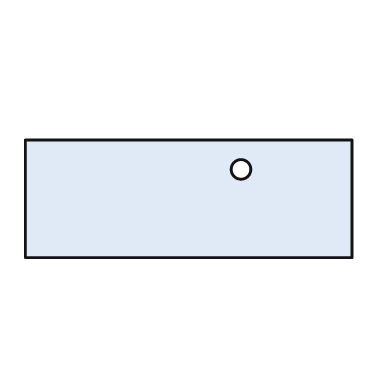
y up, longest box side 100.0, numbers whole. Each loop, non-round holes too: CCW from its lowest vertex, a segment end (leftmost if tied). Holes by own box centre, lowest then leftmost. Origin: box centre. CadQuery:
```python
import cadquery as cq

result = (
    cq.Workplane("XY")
    .moveTo(-50.0, -18.0)
    .lineTo(50.0, -18.0)
    .lineTo(50.0, 18.0)
    .lineTo(-50.0, 18.0)
    .close()
    .moveTo(16.0, 9.0)
    .circle(3.0)
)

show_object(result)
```